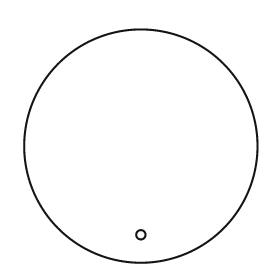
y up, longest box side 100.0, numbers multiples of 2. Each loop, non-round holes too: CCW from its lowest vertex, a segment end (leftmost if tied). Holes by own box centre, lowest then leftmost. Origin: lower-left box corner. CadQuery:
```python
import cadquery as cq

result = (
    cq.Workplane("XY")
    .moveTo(50.0, 50.0)
    .circle(50.0)
    .moveTo(50.0, 12.0)
    .circle(2.0)
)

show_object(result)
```